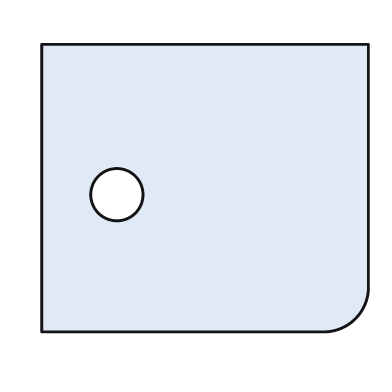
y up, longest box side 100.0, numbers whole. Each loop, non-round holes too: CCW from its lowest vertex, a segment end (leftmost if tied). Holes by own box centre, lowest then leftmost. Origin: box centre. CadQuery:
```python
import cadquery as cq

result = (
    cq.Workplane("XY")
    .moveTo(-50.0, -44.0)
    .lineTo(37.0, -44.0)
    .threePointArc((46.0, -40.0), (50.0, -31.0))
    .lineTo(50.0, 44.0)
    .lineTo(-50.0, 44.0)
    .close()
    .moveTo(-27.0, -2.0)
    .circle(8.0)
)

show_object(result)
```